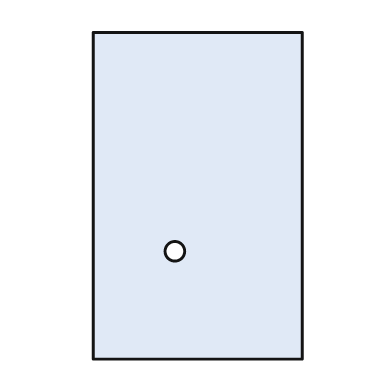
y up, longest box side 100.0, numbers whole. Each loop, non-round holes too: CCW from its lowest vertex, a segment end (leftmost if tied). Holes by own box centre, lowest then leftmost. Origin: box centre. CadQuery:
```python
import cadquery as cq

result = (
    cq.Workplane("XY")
    .moveTo(-32.0, -50.0)
    .lineTo(32.0, -50.0)
    .lineTo(32.0, 50.0)
    .lineTo(-32.0, 50.0)
    .close()
    .moveTo(-7.0, -17.0)
    .circle(3.0)
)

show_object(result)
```